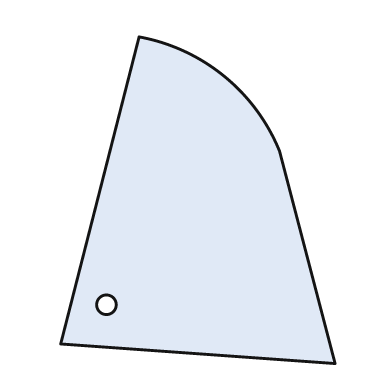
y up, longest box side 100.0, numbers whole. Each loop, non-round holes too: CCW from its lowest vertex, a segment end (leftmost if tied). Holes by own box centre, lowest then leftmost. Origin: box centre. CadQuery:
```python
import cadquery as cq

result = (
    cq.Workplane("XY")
    .moveTo(42.0, -50.0)
    .lineTo(25.0, 15.0)
    .threePointArc((8.0, 38.0), (-18.0, 50.0))
    .lineTo(-42.0, -44.0)
    .close()
    .moveTo(-28.0, -32.0)
    .circle(3.0)
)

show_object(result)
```